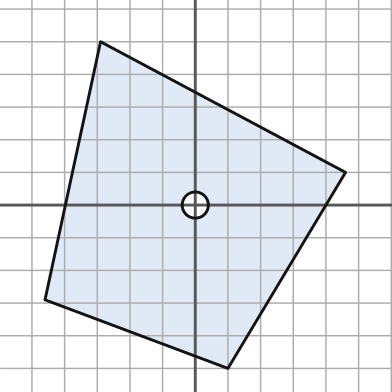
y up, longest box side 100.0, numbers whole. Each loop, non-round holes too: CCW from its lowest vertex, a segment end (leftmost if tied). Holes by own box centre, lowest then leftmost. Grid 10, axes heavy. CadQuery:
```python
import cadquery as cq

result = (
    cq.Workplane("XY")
    .moveTo(10.0, -50.0)
    .lineTo(46.0, 10.0)
    .lineTo(-29.0, 50.0)
    .lineTo(-46.0, -29.0)
    .close()
    .moveTo(0.0, 0.0)
    .circle(4.0)
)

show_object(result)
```